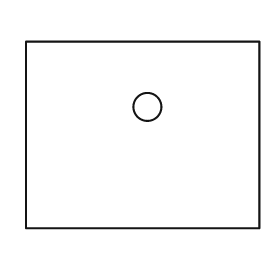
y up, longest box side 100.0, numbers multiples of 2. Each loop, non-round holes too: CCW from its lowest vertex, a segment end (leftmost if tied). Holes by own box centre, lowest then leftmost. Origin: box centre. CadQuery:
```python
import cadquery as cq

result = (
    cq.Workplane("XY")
    .moveTo(-50.0, -40.0)
    .lineTo(50.0, -40.0)
    .lineTo(50.0, 40.0)
    .lineTo(-50.0, 40.0)
    .close()
    .moveTo(2.0, 12.0)
    .circle(6.0)
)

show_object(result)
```